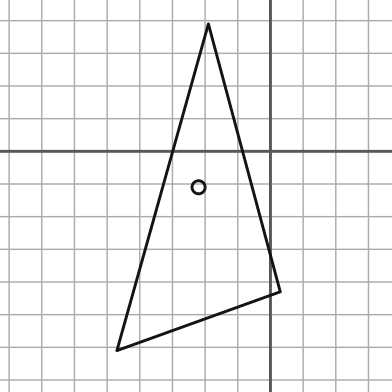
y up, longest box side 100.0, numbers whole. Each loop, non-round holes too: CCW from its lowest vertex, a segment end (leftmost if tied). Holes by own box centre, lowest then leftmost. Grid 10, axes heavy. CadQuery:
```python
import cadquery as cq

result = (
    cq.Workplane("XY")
    .moveTo(-47.0, -61.0)
    .lineTo(3.0, -43.0)
    .lineTo(-19.0, 39.0)
    .close()
    .moveTo(-22.0, -11.0)
    .circle(2.0)
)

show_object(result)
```